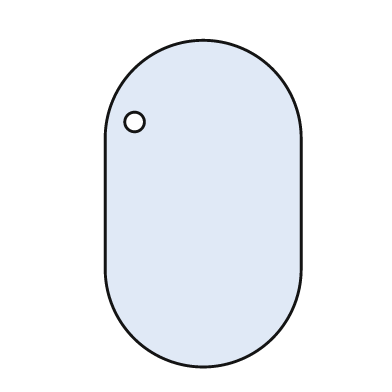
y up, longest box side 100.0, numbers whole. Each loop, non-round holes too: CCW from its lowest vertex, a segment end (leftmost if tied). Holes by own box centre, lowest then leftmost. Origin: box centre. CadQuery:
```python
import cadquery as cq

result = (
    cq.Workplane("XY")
    .moveTo(-30.0, -20.0)
    .threePointArc((0.0, -50.0), (30.0, -20.0))
    .lineTo(30.0, 20.0)
    .threePointArc((0.0, 50.0), (-30.0, 20.0))
    .close()
    .moveTo(-21.0, 25.0)
    .circle(3.0)
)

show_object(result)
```